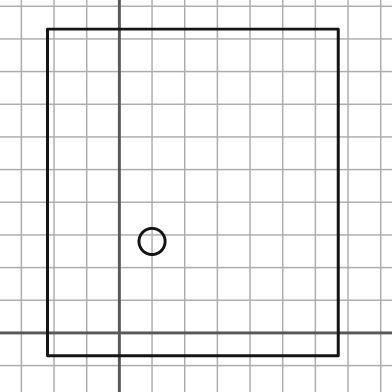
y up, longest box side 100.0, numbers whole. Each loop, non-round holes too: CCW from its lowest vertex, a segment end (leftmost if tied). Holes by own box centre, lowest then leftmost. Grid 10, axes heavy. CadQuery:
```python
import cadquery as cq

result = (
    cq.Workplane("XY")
    .moveTo(-22.0, -7.0)
    .lineTo(67.0, -7.0)
    .lineTo(67.0, 93.0)
    .lineTo(-22.0, 93.0)
    .close()
    .moveTo(10.0, 28.0)
    .circle(4.0)
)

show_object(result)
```